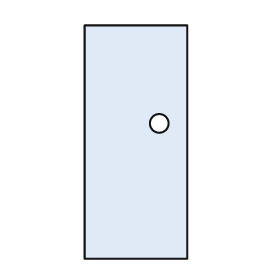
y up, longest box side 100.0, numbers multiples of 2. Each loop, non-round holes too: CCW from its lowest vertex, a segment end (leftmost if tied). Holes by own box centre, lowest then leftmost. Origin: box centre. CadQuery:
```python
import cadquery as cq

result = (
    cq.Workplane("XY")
    .moveTo(-22.0, -50.0)
    .lineTo(22.0, -50.0)
    .lineTo(22.0, 50.0)
    .lineTo(-22.0, 50.0)
    .close()
    .moveTo(10.0, 8.0)
    .circle(4.0)
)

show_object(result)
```